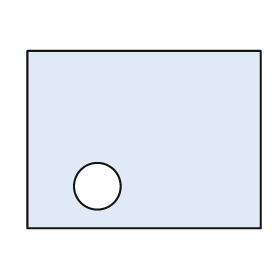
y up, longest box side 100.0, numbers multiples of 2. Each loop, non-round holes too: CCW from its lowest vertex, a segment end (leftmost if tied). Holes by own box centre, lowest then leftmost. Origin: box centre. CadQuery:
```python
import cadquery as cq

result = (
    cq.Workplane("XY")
    .moveTo(-50.0, -38.0)
    .lineTo(50.0, -38.0)
    .lineTo(50.0, 38.0)
    .lineTo(-50.0, 38.0)
    .close()
    .moveTo(-20.0, -20.0)
    .circle(10.0)
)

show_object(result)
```